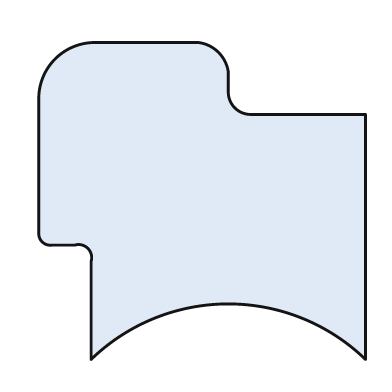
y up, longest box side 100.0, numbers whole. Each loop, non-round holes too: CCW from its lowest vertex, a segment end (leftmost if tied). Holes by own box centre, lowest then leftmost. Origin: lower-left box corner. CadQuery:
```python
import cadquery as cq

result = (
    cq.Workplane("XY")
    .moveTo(16.0, 0.0)
    .threePointArc((58.0, 17.0), (100.0, 0.0))
    .lineTo(100.0, 75.0)
    .lineTo(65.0, 75.0)
    .threePointArc((60.0, 77.0), (58.0, 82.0))
    .lineTo(58.0, 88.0)
    .threePointArc((55.0, 94.0), (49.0, 97.0))
    .lineTo(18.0, 97.0)
    .threePointArc((5.0, 92.0), (0.0, 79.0))
    .lineTo(0.0, 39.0)
    .threePointArc((1.0, 36.0), (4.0, 35.0))
    .lineTo(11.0, 35.0)
    .threePointArc((15.0, 34.0), (16.0, 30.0))
    .close()
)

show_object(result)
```